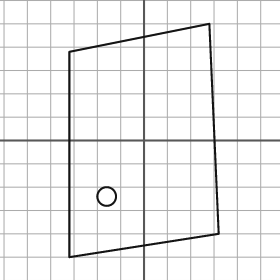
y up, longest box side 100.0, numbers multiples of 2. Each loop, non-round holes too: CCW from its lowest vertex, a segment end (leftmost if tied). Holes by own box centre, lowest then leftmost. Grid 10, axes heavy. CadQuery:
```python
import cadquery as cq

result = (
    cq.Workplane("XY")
    .moveTo(-32.0, -50.0)
    .lineTo(32.0, -40.0)
    .lineTo(28.0, 50.0)
    .lineTo(-32.0, 38.0)
    .close()
    .moveTo(-16.0, -24.0)
    .circle(4.0)
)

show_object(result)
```